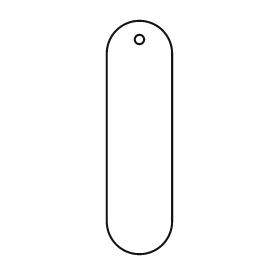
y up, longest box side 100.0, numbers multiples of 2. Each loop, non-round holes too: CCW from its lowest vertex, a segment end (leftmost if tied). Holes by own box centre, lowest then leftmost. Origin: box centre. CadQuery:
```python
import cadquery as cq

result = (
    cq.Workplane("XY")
    .moveTo(-14.0, -36.0)
    .threePointArc((0.0, -50.0), (14.0, -36.0))
    .lineTo(14.0, 36.0)
    .threePointArc((0.0, 50.0), (-14.0, 36.0))
    .close()
    .moveTo(0.0, 42.0)
    .circle(2.0)
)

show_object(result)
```